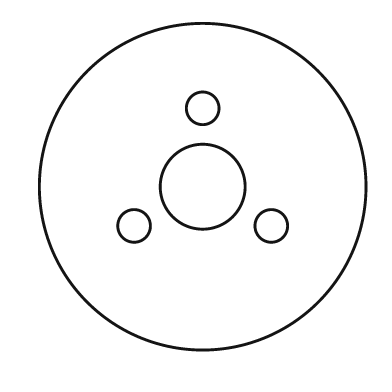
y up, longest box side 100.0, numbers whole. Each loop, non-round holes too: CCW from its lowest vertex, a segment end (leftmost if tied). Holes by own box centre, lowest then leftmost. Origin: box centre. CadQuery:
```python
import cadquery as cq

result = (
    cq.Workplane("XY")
    .moveTo(0.0, 0.0)
    .circle(50.0)
    .moveTo(-21.0, -12.0)
    .circle(5.0)
    .moveTo(21.0, -12.0)
    .circle(5.0)
    .moveTo(0.0, 0.0)
    .circle(13.0)
    .moveTo(0.0, 24.0)
    .circle(5.0)
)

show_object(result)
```